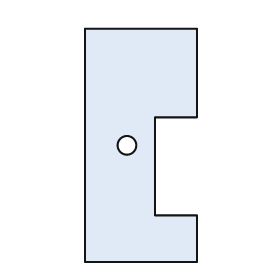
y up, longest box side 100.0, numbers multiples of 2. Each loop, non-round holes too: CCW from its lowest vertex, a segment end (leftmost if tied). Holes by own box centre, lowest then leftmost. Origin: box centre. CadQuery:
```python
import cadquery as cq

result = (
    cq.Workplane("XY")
    .moveTo(-24.0, -50.0)
    .lineTo(24.0, -50.0)
    .lineTo(24.0, -30.0)
    .lineTo(6.0, -30.0)
    .lineTo(6.0, 12.0)
    .lineTo(24.0, 12.0)
    .lineTo(24.0, 50.0)
    .lineTo(-24.0, 50.0)
    .close()
    .moveTo(-6.0, 0.0)
    .circle(4.0)
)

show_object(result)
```